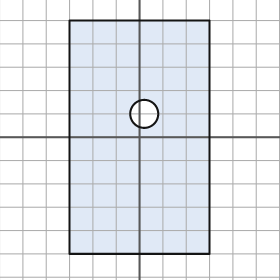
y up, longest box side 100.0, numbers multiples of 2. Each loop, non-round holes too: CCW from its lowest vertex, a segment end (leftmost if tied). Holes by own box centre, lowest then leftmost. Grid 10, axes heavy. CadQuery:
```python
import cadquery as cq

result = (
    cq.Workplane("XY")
    .moveTo(-30.0, -50.0)
    .lineTo(30.0, -50.0)
    .lineTo(30.0, 50.0)
    .lineTo(-30.0, 50.0)
    .close()
    .moveTo(2.0, 10.0)
    .circle(6.0)
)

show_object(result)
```